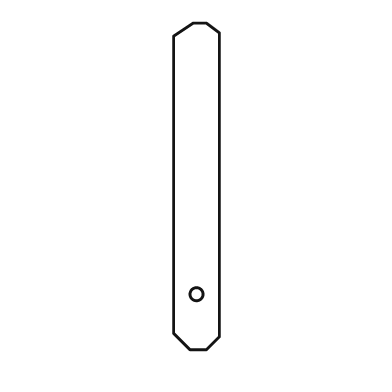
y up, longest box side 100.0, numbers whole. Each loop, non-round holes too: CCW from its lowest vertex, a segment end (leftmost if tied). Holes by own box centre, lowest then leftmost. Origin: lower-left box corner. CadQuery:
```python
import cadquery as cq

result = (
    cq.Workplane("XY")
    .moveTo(5.0, 0.0)
    .lineTo(10.0, 0.0)
    .lineTo(14.0, 4.0)
    .lineTo(14.0, 97.0)
    .lineTo(10.0, 100.0)
    .lineTo(6.0, 100.0)
    .lineTo(0.0, 96.0)
    .lineTo(0.0, 5.0)
    .close()
    .moveTo(7.0, 17.0)
    .circle(2.0)
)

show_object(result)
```